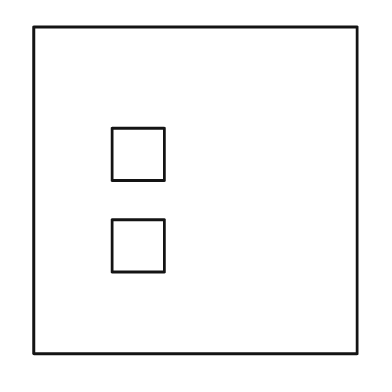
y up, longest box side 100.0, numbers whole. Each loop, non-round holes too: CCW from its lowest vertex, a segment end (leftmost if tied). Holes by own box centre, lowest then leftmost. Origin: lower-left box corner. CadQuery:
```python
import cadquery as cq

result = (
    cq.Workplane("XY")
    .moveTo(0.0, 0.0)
    .lineTo(99.0, 0.0)
    .lineTo(99.0, 100.0)
    .lineTo(0.0, 100.0)
    .close()
    .moveTo(24.0, 25.0)
    .lineTo(40.0, 25.0)
    .lineTo(40.0, 41.0)
    .lineTo(24.0, 41.0)
    .close()
    .moveTo(24.0, 53.0)
    .lineTo(40.0, 53.0)
    .lineTo(40.0, 69.0)
    .lineTo(24.0, 69.0)
    .close()
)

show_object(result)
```